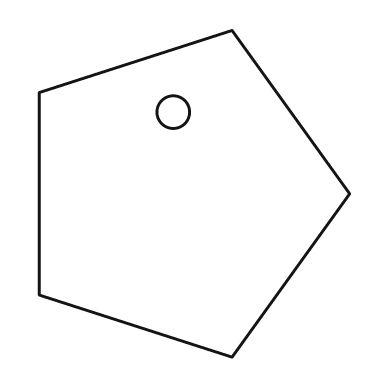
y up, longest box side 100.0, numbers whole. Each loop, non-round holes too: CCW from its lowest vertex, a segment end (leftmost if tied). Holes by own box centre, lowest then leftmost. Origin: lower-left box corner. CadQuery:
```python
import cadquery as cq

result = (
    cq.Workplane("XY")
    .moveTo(59.0, 0.0)
    .lineTo(95.0, 50.0)
    .lineTo(59.0, 100.0)
    .lineTo(0.0, 81.0)
    .lineTo(0.0, 19.0)
    .close()
    .moveTo(41.0, 75.0)
    .circle(5.0)
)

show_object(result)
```